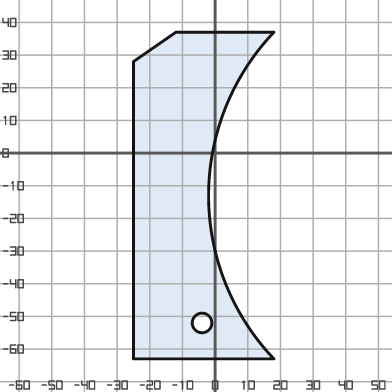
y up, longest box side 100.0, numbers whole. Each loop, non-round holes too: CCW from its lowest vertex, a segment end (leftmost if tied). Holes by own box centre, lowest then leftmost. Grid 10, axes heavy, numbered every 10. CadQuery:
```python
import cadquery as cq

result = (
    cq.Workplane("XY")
    .moveTo(-25.0, -63.0)
    .lineTo(18.0, -63.0)
    .threePointArc((-2.0, -13.0), (18.0, 37.0))
    .lineTo(-12.0, 37.0)
    .lineTo(-25.0, 28.0)
    .close()
    .moveTo(-4.0, -52.0)
    .circle(3.0)
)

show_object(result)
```